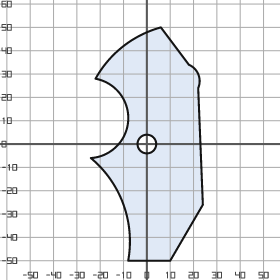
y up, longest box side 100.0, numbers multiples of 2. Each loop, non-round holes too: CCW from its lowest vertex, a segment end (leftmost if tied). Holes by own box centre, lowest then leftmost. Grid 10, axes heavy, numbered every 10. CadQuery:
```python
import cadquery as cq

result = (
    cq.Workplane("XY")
    .moveTo(-8.0, -50.0)
    .lineTo(10.0, -50.0)
    .lineTo(24.0, -26.0)
    .lineTo(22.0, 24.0)
    .threePointArc((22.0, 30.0), (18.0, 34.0))
    .lineTo(6.0, 50.0)
    .threePointArc((-10.0, 42.0), (-22.0, 28.0))
    .threePointArc((-8.0, 10.0), (-24.0, -6.0))
    .threePointArc((-10.0, -26.0), (-8.0, -50.0))
    .close()
    .moveTo(0.0, 0.0)
    .circle(4.0)
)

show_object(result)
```